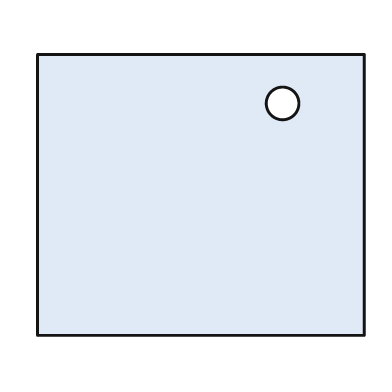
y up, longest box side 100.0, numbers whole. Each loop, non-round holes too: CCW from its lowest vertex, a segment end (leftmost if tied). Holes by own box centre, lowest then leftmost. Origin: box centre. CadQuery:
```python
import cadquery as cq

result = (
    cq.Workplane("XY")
    .moveTo(-50.0, -43.0)
    .lineTo(50.0, -43.0)
    .lineTo(50.0, 43.0)
    .lineTo(-50.0, 43.0)
    .close()
    .moveTo(25.0, 28.0)
    .circle(5.0)
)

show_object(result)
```